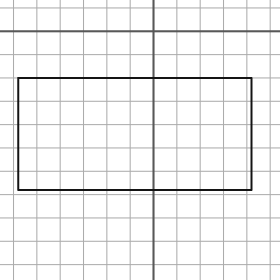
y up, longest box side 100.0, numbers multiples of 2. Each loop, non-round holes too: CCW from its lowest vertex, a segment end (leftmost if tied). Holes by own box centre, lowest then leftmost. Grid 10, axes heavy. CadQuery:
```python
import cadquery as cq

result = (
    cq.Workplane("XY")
    .moveTo(-58.0, -68.0)
    .lineTo(42.0, -68.0)
    .lineTo(42.0, -20.0)
    .lineTo(-58.0, -20.0)
    .close()
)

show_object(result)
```